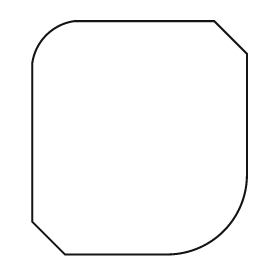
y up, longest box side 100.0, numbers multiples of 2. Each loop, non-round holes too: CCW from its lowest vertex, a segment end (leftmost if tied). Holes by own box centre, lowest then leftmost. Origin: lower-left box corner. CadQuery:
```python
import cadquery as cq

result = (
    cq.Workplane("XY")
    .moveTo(14.0, 0.0)
    .lineTo(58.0, 0.0)
    .threePointArc((82.0, 10.0), (92.0, 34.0))
    .lineTo(92.0, 86.0)
    .lineTo(78.0, 100.0)
    .lineTo(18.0, 100.0)
    .threePointArc((6.0, 94.0), (0.0, 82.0))
    .lineTo(0.0, 14.0)
    .close()
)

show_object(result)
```